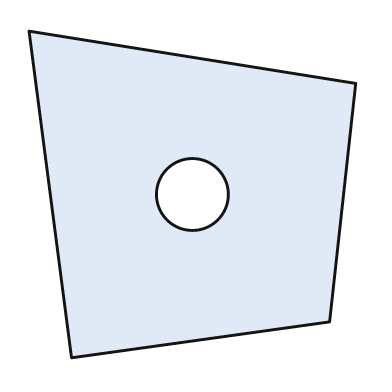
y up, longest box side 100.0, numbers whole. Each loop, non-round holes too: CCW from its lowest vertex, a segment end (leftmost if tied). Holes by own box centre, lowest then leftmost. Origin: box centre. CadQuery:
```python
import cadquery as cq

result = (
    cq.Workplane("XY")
    .moveTo(-37.0, -50.0)
    .lineTo(42.0, -39.0)
    .lineTo(50.0, 34.0)
    .lineTo(-50.0, 50.0)
    .close()
    .moveTo(0.0, 0.0)
    .circle(11.0)
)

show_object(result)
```